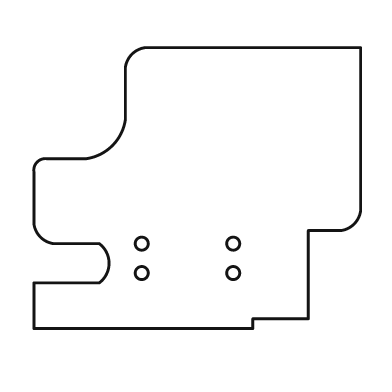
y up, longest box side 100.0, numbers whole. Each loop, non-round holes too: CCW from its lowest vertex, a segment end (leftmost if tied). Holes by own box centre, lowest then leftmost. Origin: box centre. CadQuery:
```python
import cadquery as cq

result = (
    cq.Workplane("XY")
    .moveTo(-50.0, -43.0)
    .lineTo(17.0, -43.0)
    .lineTo(17.0, -40.0)
    .lineTo(34.0, -40.0)
    .lineTo(34.0, -13.0)
    .lineTo(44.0, -13.0)
    .threePointArc((48.0, -11.0), (50.0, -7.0))
    .lineTo(50.0, 43.0)
    .lineTo(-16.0, 43.0)
    .threePointArc((-20.0, 41.0), (-22.0, 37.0))
    .lineTo(-22.0, 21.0)
    .threePointArc((-26.0, 13.0), (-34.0, 9.0))
    .lineTo(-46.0, 9.0)
    .threePointArc((-49.0, 8.0), (-50.0, 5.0))
    .lineTo(-50.0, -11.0)
    .threePointArc((-48.0, -15.0), (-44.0, -17.0))
    .lineTo(-30.0, -17.0)
    .threePointArc((-27.0, -23.0), (-30.0, -29.0))
    .lineTo(-50.0, -29.0)
    .close()
    .moveTo(-17.0, -26.0)
    .circle(2.0)
    .moveTo(11.0, -26.0)
    .circle(2.0)
    .moveTo(-17.0, -17.0)
    .circle(2.0)
    .moveTo(11.0, -17.0)
    .circle(2.0)
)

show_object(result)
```